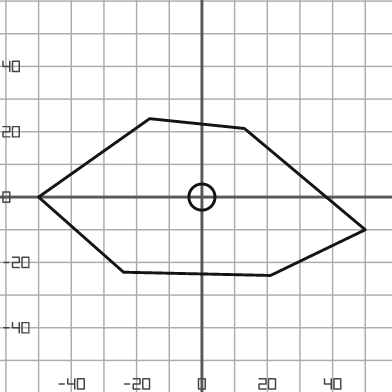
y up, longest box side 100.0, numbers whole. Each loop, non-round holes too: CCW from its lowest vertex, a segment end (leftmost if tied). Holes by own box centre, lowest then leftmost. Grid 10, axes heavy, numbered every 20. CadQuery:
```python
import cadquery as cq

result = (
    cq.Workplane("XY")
    .moveTo(21.0, -24.0)
    .lineTo(50.0, -10.0)
    .lineTo(13.0, 21.0)
    .lineTo(-16.0, 24.0)
    .lineTo(-50.0, 0.0)
    .lineTo(-24.0, -23.0)
    .close()
    .moveTo(0.0, 0.0)
    .circle(4.0)
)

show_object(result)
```